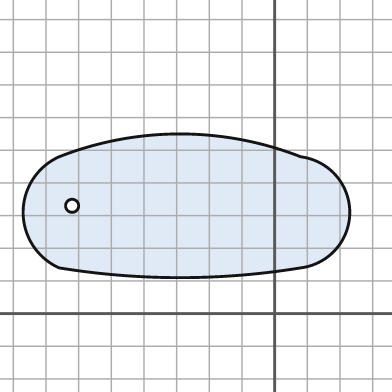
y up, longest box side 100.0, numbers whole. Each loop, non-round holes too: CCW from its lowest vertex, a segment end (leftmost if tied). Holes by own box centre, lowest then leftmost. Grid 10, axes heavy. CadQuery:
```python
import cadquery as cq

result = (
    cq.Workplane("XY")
    .moveTo(-66.0, 14.0)
    .threePointArc((-29.0, 11.0), (8.0, 14.0))
    .threePointArc((23.0, 31.0), (8.0, 48.0))
    .threePointArc((-29.0, 55.0), (-66.0, 48.0))
    .threePointArc((-77.0, 31.0), (-66.0, 14.0))
    .close()
    .moveTo(-62.0, 33.0)
    .circle(2.0)
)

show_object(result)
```